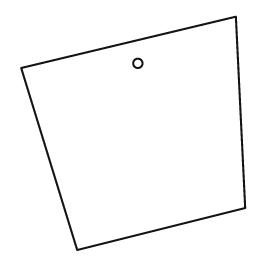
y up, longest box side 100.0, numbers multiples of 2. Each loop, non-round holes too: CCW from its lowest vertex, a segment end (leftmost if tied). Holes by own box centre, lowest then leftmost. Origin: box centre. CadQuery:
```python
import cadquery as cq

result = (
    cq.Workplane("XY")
    .moveTo(-24.0, -50.0)
    .lineTo(48.0, -32.0)
    .lineTo(44.0, 50.0)
    .lineTo(-48.0, 28.0)
    .close()
    .moveTo(2.0, 30.0)
    .circle(2.0)
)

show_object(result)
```